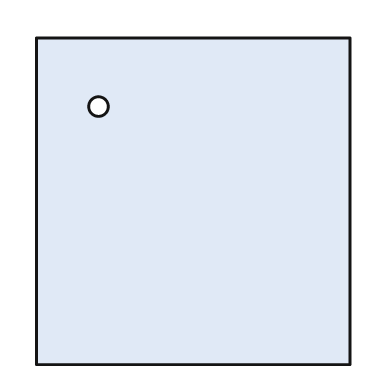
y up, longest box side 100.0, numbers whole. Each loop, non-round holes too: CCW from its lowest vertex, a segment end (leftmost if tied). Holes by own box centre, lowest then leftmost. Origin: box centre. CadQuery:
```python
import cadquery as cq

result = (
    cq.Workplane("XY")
    .moveTo(-48.0, -50.0)
    .lineTo(48.0, -50.0)
    .lineTo(48.0, 50.0)
    .lineTo(-48.0, 50.0)
    .close()
    .moveTo(-29.0, 29.0)
    .circle(3.0)
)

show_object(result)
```